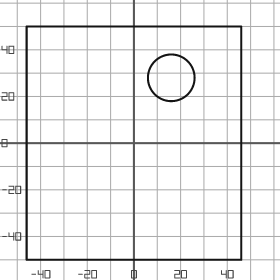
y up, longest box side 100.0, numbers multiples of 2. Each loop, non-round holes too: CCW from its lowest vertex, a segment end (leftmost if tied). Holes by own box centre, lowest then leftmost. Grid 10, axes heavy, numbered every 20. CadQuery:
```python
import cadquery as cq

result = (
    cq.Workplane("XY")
    .moveTo(-46.0, -50.0)
    .lineTo(46.0, -50.0)
    .lineTo(46.0, 50.0)
    .lineTo(-46.0, 50.0)
    .close()
    .moveTo(16.0, 28.0)
    .circle(10.0)
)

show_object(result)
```